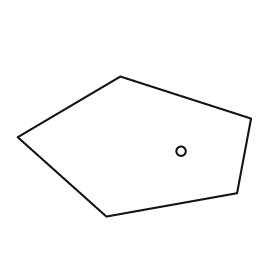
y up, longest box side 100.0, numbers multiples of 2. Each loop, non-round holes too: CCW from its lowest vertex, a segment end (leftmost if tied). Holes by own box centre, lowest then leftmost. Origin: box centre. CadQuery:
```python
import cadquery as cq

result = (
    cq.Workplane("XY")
    .moveTo(-12.0, -30.0)
    .lineTo(44.0, -20.0)
    .lineTo(50.0, 12.0)
    .lineTo(-6.0, 30.0)
    .lineTo(-50.0, 4.0)
    .close()
    .moveTo(20.0, -2.0)
    .circle(2.0)
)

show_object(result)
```